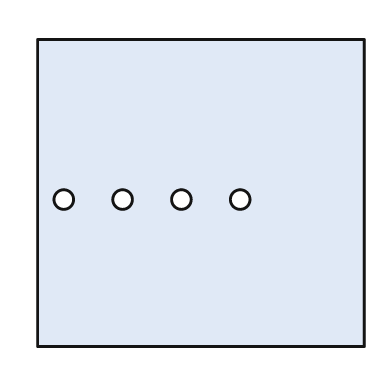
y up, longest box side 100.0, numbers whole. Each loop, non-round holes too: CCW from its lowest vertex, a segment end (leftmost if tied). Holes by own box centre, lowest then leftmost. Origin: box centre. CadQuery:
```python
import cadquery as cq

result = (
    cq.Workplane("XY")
    .moveTo(-50.0, -47.0)
    .lineTo(50.0, -47.0)
    .lineTo(50.0, 47.0)
    .lineTo(-50.0, 47.0)
    .close()
    .moveTo(-42.0, -2.0)
    .circle(3.0)
    .moveTo(-24.0, -2.0)
    .circle(3.0)
    .moveTo(-6.0, -2.0)
    .circle(3.0)
    .moveTo(12.0, -2.0)
    .circle(3.0)
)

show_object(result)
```